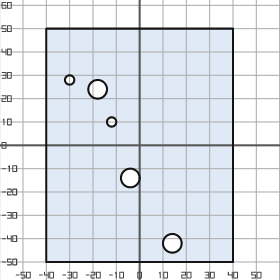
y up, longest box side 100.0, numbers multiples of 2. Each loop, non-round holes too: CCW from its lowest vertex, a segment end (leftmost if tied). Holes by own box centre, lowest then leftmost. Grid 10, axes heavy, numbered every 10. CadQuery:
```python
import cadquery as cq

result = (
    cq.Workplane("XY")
    .moveTo(-40.0, -50.0)
    .lineTo(40.0, -50.0)
    .lineTo(40.0, 50.0)
    .lineTo(-40.0, 50.0)
    .close()
    .moveTo(14.0, -42.0)
    .circle(4.0)
    .moveTo(-4.0, -14.0)
    .circle(4.0)
    .moveTo(-12.0, 10.0)
    .circle(2.0)
    .moveTo(-18.0, 24.0)
    .circle(4.0)
    .moveTo(-30.0, 28.0)
    .circle(2.0)
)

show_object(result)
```